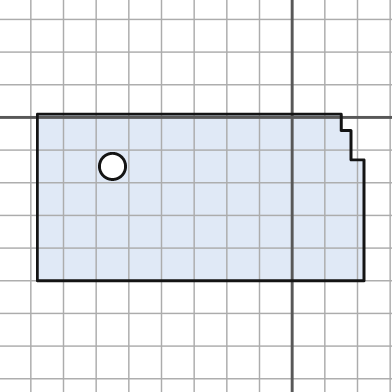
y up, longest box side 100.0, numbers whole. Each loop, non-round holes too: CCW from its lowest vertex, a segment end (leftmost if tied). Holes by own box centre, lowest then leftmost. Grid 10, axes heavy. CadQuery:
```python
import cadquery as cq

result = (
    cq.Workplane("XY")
    .moveTo(-78.0, -50.0)
    .lineTo(22.0, -50.0)
    .lineTo(22.0, -13.0)
    .lineTo(18.0, -13.0)
    .lineTo(18.0, -4.0)
    .lineTo(15.0, -4.0)
    .lineTo(15.0, 1.0)
    .lineTo(-78.0, 1.0)
    .close()
    .moveTo(-55.0, -15.0)
    .circle(4.0)
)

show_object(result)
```